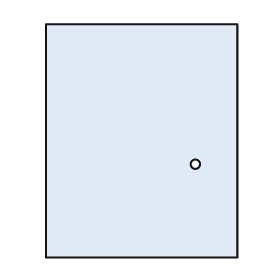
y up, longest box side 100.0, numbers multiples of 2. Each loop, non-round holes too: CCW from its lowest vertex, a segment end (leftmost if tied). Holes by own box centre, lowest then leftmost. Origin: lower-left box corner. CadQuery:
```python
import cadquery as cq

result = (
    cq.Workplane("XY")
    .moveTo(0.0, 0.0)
    .lineTo(82.0, 0.0)
    .lineTo(82.0, 100.0)
    .lineTo(0.0, 100.0)
    .close()
    .moveTo(64.0, 40.0)
    .circle(2.0)
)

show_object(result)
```